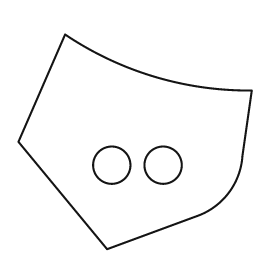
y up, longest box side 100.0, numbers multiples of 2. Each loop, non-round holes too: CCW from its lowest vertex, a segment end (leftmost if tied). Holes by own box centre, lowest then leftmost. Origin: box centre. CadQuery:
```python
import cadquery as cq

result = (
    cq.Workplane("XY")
    .moveTo(-12.0, -46.0)
    .lineTo(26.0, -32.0)
    .threePointArc((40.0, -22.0), (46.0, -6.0))
    .lineTo(50.0, 22.0)
    .threePointArc((8.0, 28.0), (-30.0, 46.0))
    .lineTo(-50.0, 0.0)
    .close()
    .moveTo(-10.0, -10.0)
    .circle(8.0)
    .moveTo(12.0, -10.0)
    .circle(8.0)
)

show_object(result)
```